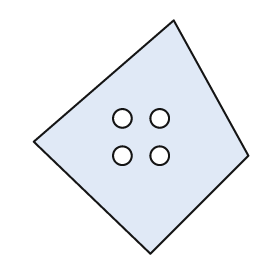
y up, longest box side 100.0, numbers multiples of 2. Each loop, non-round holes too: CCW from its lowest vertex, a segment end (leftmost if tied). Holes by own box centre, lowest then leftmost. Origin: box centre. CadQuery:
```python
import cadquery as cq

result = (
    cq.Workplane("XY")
    .moveTo(4.0, -50.0)
    .lineTo(46.0, -8.0)
    .lineTo(14.0, 50.0)
    .lineTo(-46.0, -2.0)
    .close()
    .moveTo(-8.0, -8.0)
    .circle(4.0)
    .moveTo(8.0, -8.0)
    .circle(4.0)
    .moveTo(-8.0, 8.0)
    .circle(4.0)
    .moveTo(8.0, 8.0)
    .circle(4.0)
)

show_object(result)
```